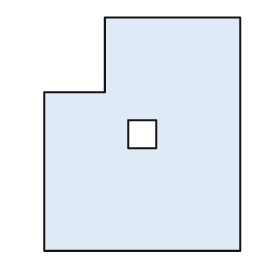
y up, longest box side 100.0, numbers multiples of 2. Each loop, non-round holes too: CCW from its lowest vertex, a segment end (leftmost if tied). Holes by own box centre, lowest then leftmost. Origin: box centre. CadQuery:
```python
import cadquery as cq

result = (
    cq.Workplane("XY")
    .moveTo(-42.0, -50.0)
    .lineTo(42.0, -50.0)
    .lineTo(42.0, 50.0)
    .lineTo(-16.0, 50.0)
    .lineTo(-16.0, 18.0)
    .lineTo(-42.0, 18.0)
    .close()
    .moveTo(-6.0, -6.0)
    .lineTo(6.0, -6.0)
    .lineTo(6.0, 6.0)
    .lineTo(-6.0, 6.0)
    .close()
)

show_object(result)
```